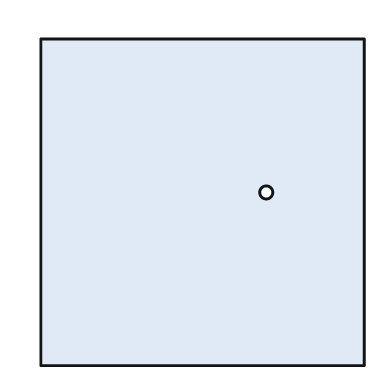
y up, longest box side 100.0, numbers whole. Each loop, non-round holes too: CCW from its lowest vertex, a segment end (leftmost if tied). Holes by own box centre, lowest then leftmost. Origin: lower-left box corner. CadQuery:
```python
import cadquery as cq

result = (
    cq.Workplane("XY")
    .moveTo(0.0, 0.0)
    .lineTo(99.0, 0.0)
    .lineTo(99.0, 100.0)
    .lineTo(0.0, 100.0)
    .close()
    .moveTo(69.0, 53.0)
    .circle(2.0)
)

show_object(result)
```